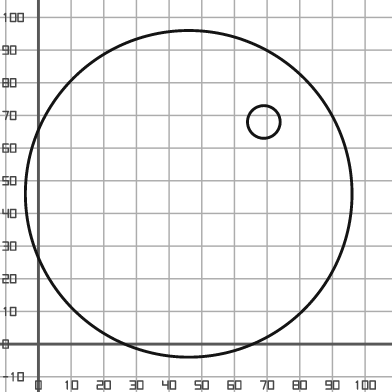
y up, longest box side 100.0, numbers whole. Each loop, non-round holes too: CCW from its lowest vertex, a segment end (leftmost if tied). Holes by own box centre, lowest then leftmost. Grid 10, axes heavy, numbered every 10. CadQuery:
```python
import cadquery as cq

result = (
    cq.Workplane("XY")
    .moveTo(46.0, 46.0)
    .circle(50.0)
    .moveTo(69.0, 68.0)
    .circle(5.0)
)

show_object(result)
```